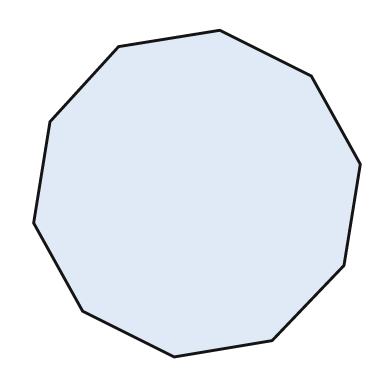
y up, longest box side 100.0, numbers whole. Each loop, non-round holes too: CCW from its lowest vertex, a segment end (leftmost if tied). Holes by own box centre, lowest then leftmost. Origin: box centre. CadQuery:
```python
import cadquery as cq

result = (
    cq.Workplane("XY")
    .moveTo(-7.0, -50.0)
    .lineTo(23.0, -45.0)
    .lineTo(45.0, -22.0)
    .lineTo(50.0, 9.0)
    .lineTo(35.0, 36.0)
    .lineTo(7.0, 50.0)
    .lineTo(-24.0, 45.0)
    .lineTo(-45.0, 22.0)
    .lineTo(-50.0, -9.0)
    .lineTo(-35.0, -36.0)
    .close()
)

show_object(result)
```